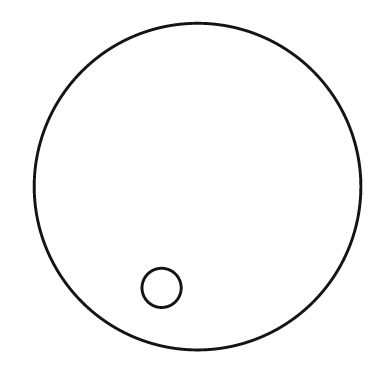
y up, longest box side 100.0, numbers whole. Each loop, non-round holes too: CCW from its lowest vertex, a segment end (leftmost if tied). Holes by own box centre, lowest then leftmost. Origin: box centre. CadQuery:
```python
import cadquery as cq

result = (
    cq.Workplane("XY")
    .moveTo(0.0, 0.0)
    .circle(50.0)
    .moveTo(-11.0, -31.0)
    .circle(6.0)
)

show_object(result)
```